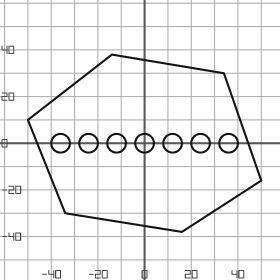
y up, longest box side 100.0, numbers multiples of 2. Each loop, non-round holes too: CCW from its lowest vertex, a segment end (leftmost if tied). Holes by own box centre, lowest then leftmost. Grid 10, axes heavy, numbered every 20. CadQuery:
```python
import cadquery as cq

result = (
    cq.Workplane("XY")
    .moveTo(16.0, -38.0)
    .lineTo(50.0, -16.0)
    .lineTo(34.0, 30.0)
    .lineTo(-14.0, 38.0)
    .lineTo(-50.0, 10.0)
    .lineTo(-34.0, -30.0)
    .close()
    .moveTo(-36.0, 0.0)
    .circle(4.0)
    .moveTo(-24.0, 0.0)
    .circle(4.0)
    .moveTo(-12.0, 0.0)
    .circle(4.0)
    .moveTo(0.0, 0.0)
    .circle(4.0)
    .moveTo(12.0, 0.0)
    .circle(4.0)
    .moveTo(24.0, 0.0)
    .circle(4.0)
    .moveTo(36.0, 0.0)
    .circle(4.0)
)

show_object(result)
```